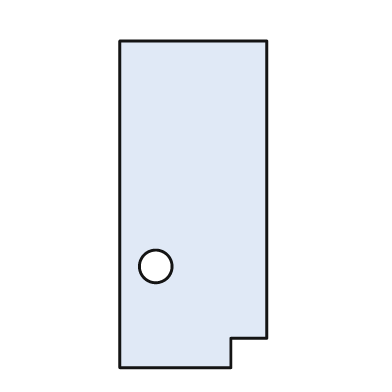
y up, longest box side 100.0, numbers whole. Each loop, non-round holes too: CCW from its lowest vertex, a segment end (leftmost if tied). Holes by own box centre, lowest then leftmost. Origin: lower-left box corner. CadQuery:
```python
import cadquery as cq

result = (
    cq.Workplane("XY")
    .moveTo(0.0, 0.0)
    .lineTo(34.0, 0.0)
    .lineTo(34.0, 9.0)
    .lineTo(45.0, 9.0)
    .lineTo(45.0, 100.0)
    .lineTo(0.0, 100.0)
    .close()
    .moveTo(11.0, 31.0)
    .circle(5.0)
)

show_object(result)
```